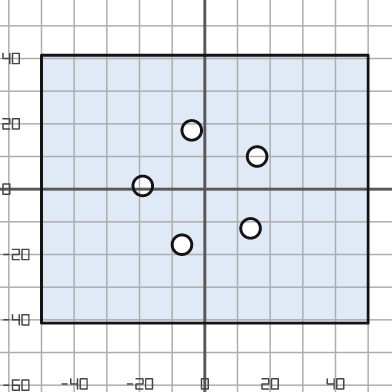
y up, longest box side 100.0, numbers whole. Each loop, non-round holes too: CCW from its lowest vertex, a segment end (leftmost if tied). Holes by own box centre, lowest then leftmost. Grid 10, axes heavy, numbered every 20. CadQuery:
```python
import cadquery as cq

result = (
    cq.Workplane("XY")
    .moveTo(-50.0, -41.0)
    .lineTo(50.0, -41.0)
    .lineTo(50.0, 41.0)
    .lineTo(-50.0, 41.0)
    .close()
    .moveTo(-7.0, -17.0)
    .circle(3.0)
    .moveTo(14.0, -12.0)
    .circle(3.0)
    .moveTo(-19.0, 1.0)
    .circle(3.0)
    .moveTo(16.0, 10.0)
    .circle(3.0)
    .moveTo(-4.0, 18.0)
    .circle(3.0)
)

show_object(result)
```